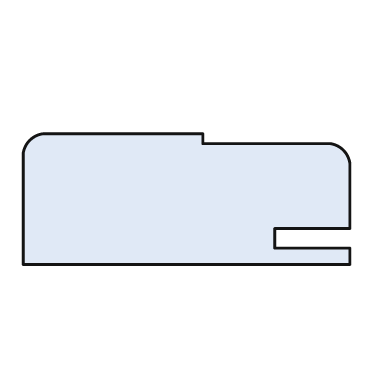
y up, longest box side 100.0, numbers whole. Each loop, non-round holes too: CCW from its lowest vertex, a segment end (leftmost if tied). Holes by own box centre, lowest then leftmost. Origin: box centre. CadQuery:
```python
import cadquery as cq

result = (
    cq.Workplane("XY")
    .moveTo(-50.0, -20.0)
    .lineTo(50.0, -20.0)
    .lineTo(50.0, -15.0)
    .lineTo(27.0, -15.0)
    .lineTo(27.0, -9.0)
    .lineTo(50.0, -9.0)
    .lineTo(50.0, 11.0)
    .threePointArc((48.0, 15.0), (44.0, 17.0))
    .lineTo(5.0, 17.0)
    .lineTo(5.0, 20.0)
    .lineTo(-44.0, 20.0)
    .threePointArc((-48.0, 18.0), (-50.0, 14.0))
    .close()
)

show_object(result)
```